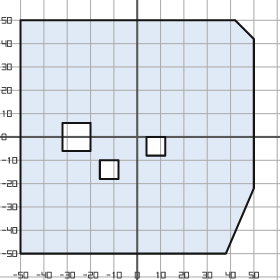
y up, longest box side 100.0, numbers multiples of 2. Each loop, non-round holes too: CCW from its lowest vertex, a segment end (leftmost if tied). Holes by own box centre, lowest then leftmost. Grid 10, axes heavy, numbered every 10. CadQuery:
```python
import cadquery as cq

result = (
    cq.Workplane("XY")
    .moveTo(-50.0, -50.0)
    .lineTo(38.0, -50.0)
    .lineTo(50.0, -22.0)
    .lineTo(50.0, 42.0)
    .lineTo(42.0, 50.0)
    .lineTo(-50.0, 50.0)
    .close()
    .moveTo(-16.0, -18.0)
    .lineTo(-8.0, -18.0)
    .lineTo(-8.0, -10.0)
    .lineTo(-16.0, -10.0)
    .close()
    .moveTo(4.0, -8.0)
    .lineTo(12.0, -8.0)
    .lineTo(12.0, 0.0)
    .lineTo(4.0, 0.0)
    .close()
    .moveTo(-32.0, -6.0)
    .lineTo(-20.0, -6.0)
    .lineTo(-20.0, 6.0)
    .lineTo(-32.0, 6.0)
    .close()
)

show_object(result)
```